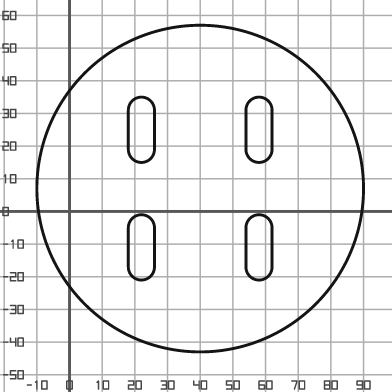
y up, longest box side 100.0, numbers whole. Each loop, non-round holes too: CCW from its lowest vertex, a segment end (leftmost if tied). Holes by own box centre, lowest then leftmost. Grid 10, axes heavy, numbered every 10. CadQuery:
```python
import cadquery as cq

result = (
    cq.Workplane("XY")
    .moveTo(40.0, 7.0)
    .circle(50.0)
    .moveTo(18.0, -17.0)
    .threePointArc((22.0, -21.0), (26.0, -17.0))
    .lineTo(26.0, -5.0)
    .threePointArc((22.0, -1.0), (18.0, -5.0))
    .close()
    .moveTo(54.0, -17.0)
    .threePointArc((58.0, -21.0), (62.0, -17.0))
    .lineTo(62.0, -5.0)
    .threePointArc((58.0, -1.0), (54.0, -5.0))
    .close()
    .moveTo(18.0, 19.0)
    .threePointArc((22.0, 15.0), (26.0, 19.0))
    .lineTo(26.0, 31.0)
    .threePointArc((22.0, 35.0), (18.0, 31.0))
    .close()
    .moveTo(54.0, 19.0)
    .threePointArc((58.0, 15.0), (62.0, 19.0))
    .lineTo(62.0, 31.0)
    .threePointArc((58.0, 35.0), (54.0, 31.0))
    .close()
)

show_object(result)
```